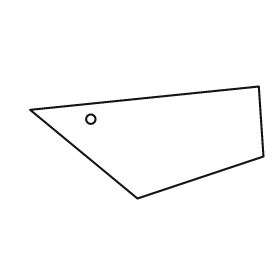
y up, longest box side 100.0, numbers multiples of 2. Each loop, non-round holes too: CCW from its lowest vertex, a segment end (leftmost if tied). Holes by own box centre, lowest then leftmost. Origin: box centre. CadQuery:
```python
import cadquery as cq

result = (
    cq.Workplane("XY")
    .moveTo(-4.0, -24.0)
    .lineTo(50.0, -6.0)
    .lineTo(48.0, 24.0)
    .lineTo(-50.0, 14.0)
    .close()
    .moveTo(-24.0, 10.0)
    .circle(2.0)
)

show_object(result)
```